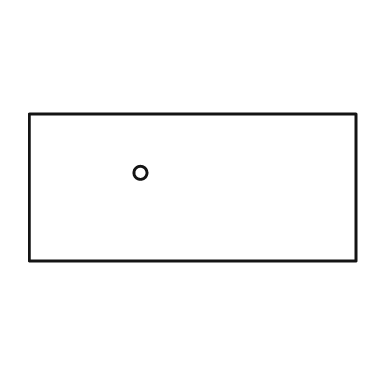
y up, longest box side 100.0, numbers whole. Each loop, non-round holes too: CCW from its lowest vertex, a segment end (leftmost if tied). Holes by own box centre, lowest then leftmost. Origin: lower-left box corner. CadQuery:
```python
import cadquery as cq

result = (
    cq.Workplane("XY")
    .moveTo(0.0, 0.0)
    .lineTo(100.0, 0.0)
    .lineTo(100.0, 45.0)
    .lineTo(0.0, 45.0)
    .close()
    .moveTo(34.0, 27.0)
    .circle(2.0)
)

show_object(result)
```